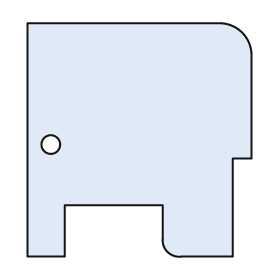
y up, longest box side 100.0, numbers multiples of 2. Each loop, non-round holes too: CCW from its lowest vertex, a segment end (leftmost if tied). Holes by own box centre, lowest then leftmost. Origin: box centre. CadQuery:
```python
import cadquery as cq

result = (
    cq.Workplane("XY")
    .moveTo(-48.0, -50.0)
    .lineTo(-32.0, -50.0)
    .lineTo(-32.0, -28.0)
    .lineTo(10.0, -28.0)
    .lineTo(10.0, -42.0)
    .threePointArc((12.0, -48.0), (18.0, -50.0))
    .lineTo(40.0, -50.0)
    .lineTo(40.0, -8.0)
    .lineTo(48.0, -8.0)
    .lineTo(48.0, 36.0)
    .threePointArc((44.0, 46.0), (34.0, 50.0))
    .lineTo(-48.0, 50.0)
    .close()
    .moveTo(-38.0, -2.0)
    .circle(4.0)
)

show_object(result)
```